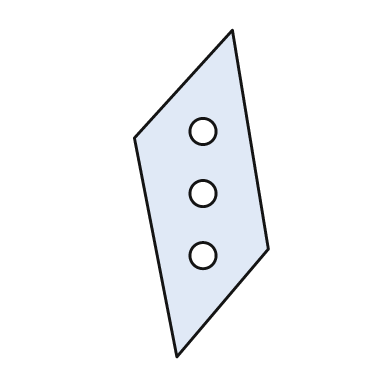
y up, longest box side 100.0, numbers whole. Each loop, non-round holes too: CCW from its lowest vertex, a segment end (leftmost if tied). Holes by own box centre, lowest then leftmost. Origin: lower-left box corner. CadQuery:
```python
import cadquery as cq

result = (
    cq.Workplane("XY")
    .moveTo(13.0, 0.0)
    .lineTo(41.0, 33.0)
    .lineTo(30.0, 100.0)
    .lineTo(0.0, 67.0)
    .close()
    .moveTo(21.0, 31.0)
    .circle(4.0)
    .moveTo(21.0, 50.0)
    .circle(4.0)
    .moveTo(21.0, 69.0)
    .circle(4.0)
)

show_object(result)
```